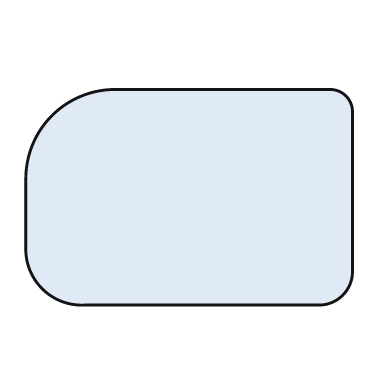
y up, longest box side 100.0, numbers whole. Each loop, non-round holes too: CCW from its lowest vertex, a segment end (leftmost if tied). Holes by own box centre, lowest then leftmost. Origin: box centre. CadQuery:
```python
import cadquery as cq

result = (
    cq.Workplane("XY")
    .moveTo(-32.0, -33.0)
    .lineTo(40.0, -33.0)
    .threePointArc((47.0, -30.0), (50.0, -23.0))
    .lineTo(50.0, 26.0)
    .threePointArc((48.0, 31.0), (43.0, 33.0))
    .lineTo(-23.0, 33.0)
    .threePointArc((-42.0, 25.0), (-50.0, 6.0))
    .lineTo(-50.0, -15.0)
    .threePointArc((-45.0, -28.0), (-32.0, -33.0))
    .close()
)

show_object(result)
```